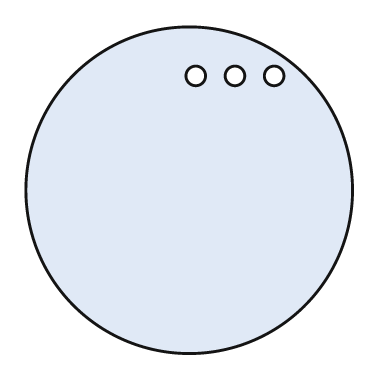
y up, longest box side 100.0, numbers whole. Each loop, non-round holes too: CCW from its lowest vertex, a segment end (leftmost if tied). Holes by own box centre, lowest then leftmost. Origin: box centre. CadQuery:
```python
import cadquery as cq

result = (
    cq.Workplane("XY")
    .moveTo(0.0, 0.0)
    .circle(50.0)
    .moveTo(2.0, 35.0)
    .circle(3.0)
    .moveTo(14.0, 35.0)
    .circle(3.0)
    .moveTo(26.0, 35.0)
    .circle(3.0)
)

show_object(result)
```